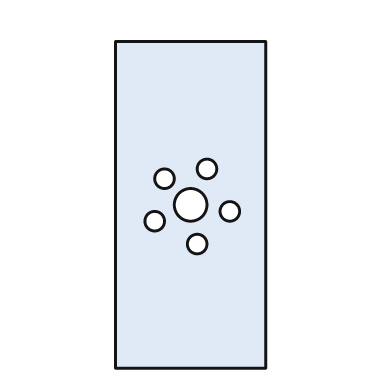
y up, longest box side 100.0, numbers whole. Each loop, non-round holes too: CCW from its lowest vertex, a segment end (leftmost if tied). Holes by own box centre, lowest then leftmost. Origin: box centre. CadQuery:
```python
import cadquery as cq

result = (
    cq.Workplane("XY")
    .moveTo(-23.0, -50.0)
    .lineTo(23.0, -50.0)
    .lineTo(23.0, 50.0)
    .lineTo(-23.0, 50.0)
    .close()
    .moveTo(2.0, -12.0)
    .circle(3.0)
    .moveTo(-11.0, -5.0)
    .circle(3.0)
    .moveTo(12.0, -2.0)
    .circle(3.0)
    .moveTo(0.0, 0.0)
    .circle(5.0)
    .moveTo(-8.0, 8.0)
    .circle(3.0)
    .moveTo(5.0, 11.0)
    .circle(3.0)
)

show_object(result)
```